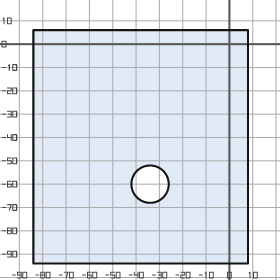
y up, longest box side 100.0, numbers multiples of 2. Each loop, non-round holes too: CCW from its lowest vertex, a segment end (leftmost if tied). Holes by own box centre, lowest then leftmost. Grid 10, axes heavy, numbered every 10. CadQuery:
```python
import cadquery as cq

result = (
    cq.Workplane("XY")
    .moveTo(-84.0, -94.0)
    .lineTo(8.0, -94.0)
    .lineTo(8.0, 6.0)
    .lineTo(-84.0, 6.0)
    .close()
    .moveTo(-34.0, -60.0)
    .circle(8.0)
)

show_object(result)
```